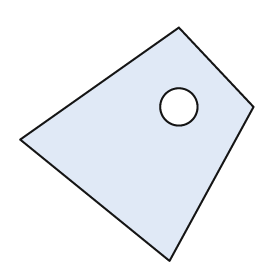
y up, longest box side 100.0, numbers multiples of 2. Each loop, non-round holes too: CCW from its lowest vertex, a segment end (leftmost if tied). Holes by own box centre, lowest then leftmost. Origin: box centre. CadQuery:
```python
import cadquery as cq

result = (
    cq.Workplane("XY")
    .moveTo(14.0, -50.0)
    .lineTo(50.0, 16.0)
    .lineTo(18.0, 50.0)
    .lineTo(-50.0, 2.0)
    .close()
    .moveTo(18.0, 16.0)
    .circle(8.0)
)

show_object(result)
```